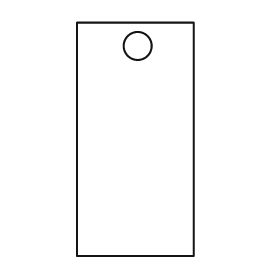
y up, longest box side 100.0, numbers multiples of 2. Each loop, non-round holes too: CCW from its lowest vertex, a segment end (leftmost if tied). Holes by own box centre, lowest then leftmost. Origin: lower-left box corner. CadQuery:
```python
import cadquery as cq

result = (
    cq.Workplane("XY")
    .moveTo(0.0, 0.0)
    .lineTo(50.0, 0.0)
    .lineTo(50.0, 100.0)
    .lineTo(0.0, 100.0)
    .close()
    .moveTo(26.0, 90.0)
    .circle(6.0)
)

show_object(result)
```